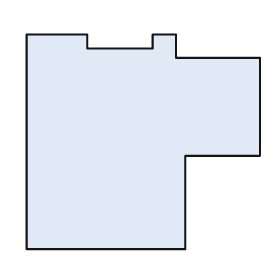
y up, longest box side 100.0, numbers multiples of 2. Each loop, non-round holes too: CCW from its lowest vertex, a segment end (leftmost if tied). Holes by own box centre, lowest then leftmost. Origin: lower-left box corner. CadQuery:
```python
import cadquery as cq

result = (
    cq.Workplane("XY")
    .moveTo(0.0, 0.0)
    .lineTo(68.0, 0.0)
    .lineTo(68.0, 40.0)
    .lineTo(100.0, 40.0)
    .lineTo(100.0, 82.0)
    .lineTo(64.0, 82.0)
    .lineTo(64.0, 92.0)
    .lineTo(54.0, 92.0)
    .lineTo(54.0, 86.0)
    .lineTo(26.0, 86.0)
    .lineTo(26.0, 92.0)
    .lineTo(0.0, 92.0)
    .close()
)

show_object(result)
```